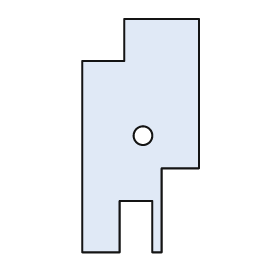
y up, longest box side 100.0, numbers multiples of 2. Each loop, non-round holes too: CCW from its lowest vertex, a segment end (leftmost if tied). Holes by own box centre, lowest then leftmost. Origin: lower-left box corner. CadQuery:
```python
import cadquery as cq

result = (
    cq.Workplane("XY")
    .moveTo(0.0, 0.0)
    .lineTo(16.0, 0.0)
    .lineTo(16.0, 22.0)
    .lineTo(30.0, 22.0)
    .lineTo(30.0, 0.0)
    .lineTo(34.0, 0.0)
    .lineTo(34.0, 36.0)
    .lineTo(50.0, 36.0)
    .lineTo(50.0, 100.0)
    .lineTo(18.0, 100.0)
    .lineTo(18.0, 82.0)
    .lineTo(0.0, 82.0)
    .close()
    .moveTo(26.0, 50.0)
    .circle(4.0)
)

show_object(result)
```